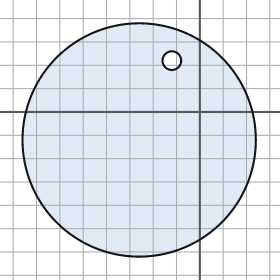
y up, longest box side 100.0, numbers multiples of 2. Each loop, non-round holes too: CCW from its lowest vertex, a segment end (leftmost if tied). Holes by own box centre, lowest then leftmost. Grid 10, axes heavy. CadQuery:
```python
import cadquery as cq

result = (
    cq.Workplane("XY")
    .moveTo(-26.0, -12.0)
    .circle(50.0)
    .moveTo(-12.0, 22.0)
    .circle(4.0)
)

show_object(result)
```